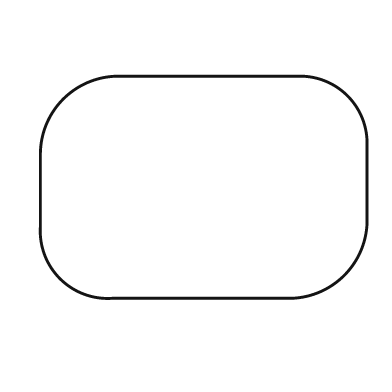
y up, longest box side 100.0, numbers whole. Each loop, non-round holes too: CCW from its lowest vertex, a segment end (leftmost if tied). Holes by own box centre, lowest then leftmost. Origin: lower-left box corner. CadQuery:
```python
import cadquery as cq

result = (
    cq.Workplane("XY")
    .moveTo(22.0, 0.0)
    .lineTo(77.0, 0.0)
    .threePointArc((93.0, 7.0), (100.0, 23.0))
    .lineTo(100.0, 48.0)
    .threePointArc((94.0, 62.0), (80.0, 68.0))
    .lineTo(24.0, 68.0)
    .threePointArc((7.0, 61.0), (0.0, 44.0))
    .lineTo(0.0, 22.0)
    .threePointArc((6.0, 6.0), (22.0, 0.0))
    .close()
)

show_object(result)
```